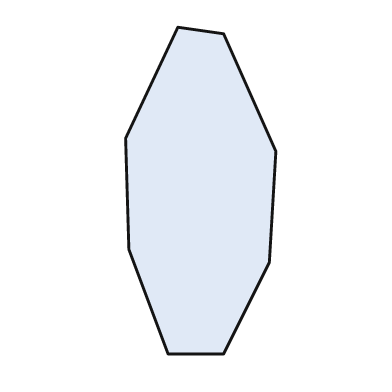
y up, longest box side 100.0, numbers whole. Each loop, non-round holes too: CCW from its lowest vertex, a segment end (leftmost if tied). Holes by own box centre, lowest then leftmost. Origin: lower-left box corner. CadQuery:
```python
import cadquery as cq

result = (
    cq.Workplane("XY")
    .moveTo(13.0, 0.0)
    .lineTo(30.0, 0.0)
    .lineTo(44.0, 28.0)
    .lineTo(46.0, 62.0)
    .lineTo(30.0, 98.0)
    .lineTo(16.0, 100.0)
    .lineTo(0.0, 66.0)
    .lineTo(1.0, 32.0)
    .close()
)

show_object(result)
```